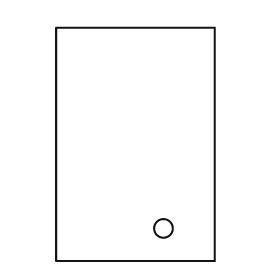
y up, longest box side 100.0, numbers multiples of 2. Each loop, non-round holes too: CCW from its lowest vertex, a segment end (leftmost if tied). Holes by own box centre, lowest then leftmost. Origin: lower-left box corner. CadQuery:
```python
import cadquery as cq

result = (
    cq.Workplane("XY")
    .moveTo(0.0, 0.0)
    .lineTo(68.0, 0.0)
    .lineTo(68.0, 100.0)
    .lineTo(0.0, 100.0)
    .close()
    .moveTo(46.0, 14.0)
    .circle(4.0)
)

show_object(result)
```